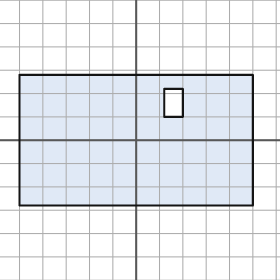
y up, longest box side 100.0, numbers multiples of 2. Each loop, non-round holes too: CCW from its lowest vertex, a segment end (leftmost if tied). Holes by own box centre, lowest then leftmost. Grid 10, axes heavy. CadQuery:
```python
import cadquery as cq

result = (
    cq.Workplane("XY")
    .moveTo(-50.0, -28.0)
    .lineTo(50.0, -28.0)
    .lineTo(50.0, 28.0)
    .lineTo(-50.0, 28.0)
    .close()
    .moveTo(12.0, 10.0)
    .lineTo(20.0, 10.0)
    .lineTo(20.0, 22.0)
    .lineTo(12.0, 22.0)
    .close()
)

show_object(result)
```